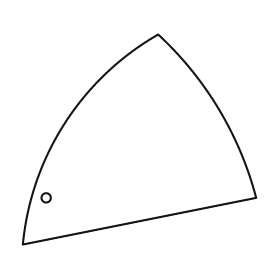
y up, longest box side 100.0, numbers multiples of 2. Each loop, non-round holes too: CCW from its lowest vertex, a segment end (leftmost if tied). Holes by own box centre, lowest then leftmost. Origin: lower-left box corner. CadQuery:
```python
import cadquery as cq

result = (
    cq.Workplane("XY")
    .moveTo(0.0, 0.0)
    .lineTo(100.0, 20.0)
    .threePointArc((84.0, 58.0), (58.0, 90.0))
    .threePointArc((18.0, 52.0), (0.0, 0.0))
    .close()
    .moveTo(10.0, 20.0)
    .circle(2.0)
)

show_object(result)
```